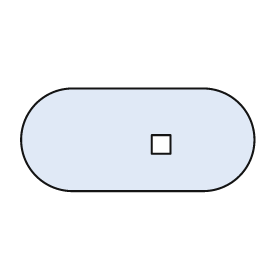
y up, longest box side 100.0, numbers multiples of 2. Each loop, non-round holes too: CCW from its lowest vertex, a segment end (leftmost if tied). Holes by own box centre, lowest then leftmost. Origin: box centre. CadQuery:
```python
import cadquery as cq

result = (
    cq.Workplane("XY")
    .moveTo(-28.0, -22.0)
    .lineTo(28.0, -22.0)
    .threePointArc((50.0, 0.0), (28.0, 22.0))
    .lineTo(-28.0, 22.0)
    .threePointArc((-50.0, 0.0), (-28.0, -22.0))
    .close()
    .moveTo(6.0, -6.0)
    .lineTo(14.0, -6.0)
    .lineTo(14.0, 2.0)
    .lineTo(6.0, 2.0)
    .close()
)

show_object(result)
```